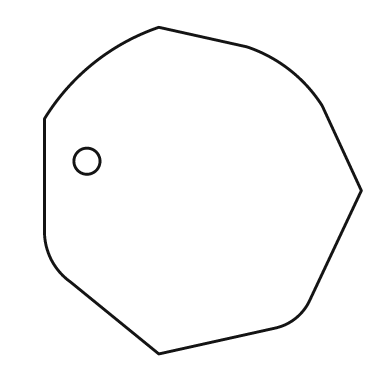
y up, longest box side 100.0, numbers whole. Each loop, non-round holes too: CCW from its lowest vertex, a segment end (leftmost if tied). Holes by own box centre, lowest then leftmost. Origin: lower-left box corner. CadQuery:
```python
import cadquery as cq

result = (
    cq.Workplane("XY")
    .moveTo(35.0, 0.0)
    .lineTo(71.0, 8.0)
    .threePointArc((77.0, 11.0), (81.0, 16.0))
    .lineTo(97.0, 50.0)
    .lineTo(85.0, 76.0)
    .threePointArc((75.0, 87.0), (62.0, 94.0))
    .lineTo(35.0, 100.0)
    .threePointArc((15.0, 89.0), (0.0, 72.0))
    .lineTo(0.0, 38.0)
    .threePointArc((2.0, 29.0), (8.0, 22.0))
    .close()
    .moveTo(13.0, 59.0)
    .circle(4.0)
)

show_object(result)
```